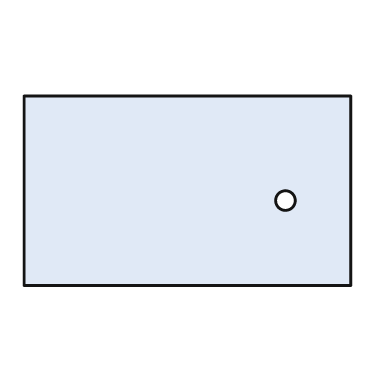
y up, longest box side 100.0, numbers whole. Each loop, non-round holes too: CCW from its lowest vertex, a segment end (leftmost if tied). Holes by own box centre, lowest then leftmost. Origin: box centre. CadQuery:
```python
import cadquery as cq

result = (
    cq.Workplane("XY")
    .moveTo(-50.0, -29.0)
    .lineTo(50.0, -29.0)
    .lineTo(50.0, 29.0)
    .lineTo(-50.0, 29.0)
    .close()
    .moveTo(30.0, -3.0)
    .circle(3.0)
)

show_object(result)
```